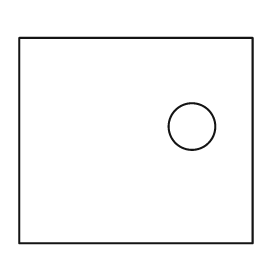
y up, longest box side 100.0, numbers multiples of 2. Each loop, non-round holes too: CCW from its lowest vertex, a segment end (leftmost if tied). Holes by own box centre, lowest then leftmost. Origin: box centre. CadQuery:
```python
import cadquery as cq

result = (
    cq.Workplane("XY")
    .moveTo(-50.0, -44.0)
    .lineTo(50.0, -44.0)
    .lineTo(50.0, 44.0)
    .lineTo(-50.0, 44.0)
    .close()
    .moveTo(24.0, 6.0)
    .circle(10.0)
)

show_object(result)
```